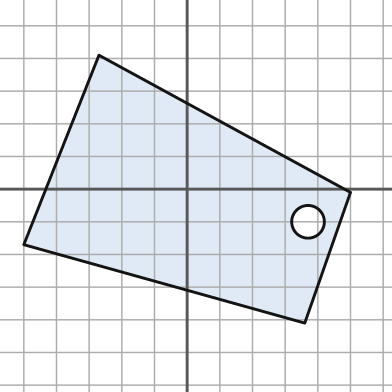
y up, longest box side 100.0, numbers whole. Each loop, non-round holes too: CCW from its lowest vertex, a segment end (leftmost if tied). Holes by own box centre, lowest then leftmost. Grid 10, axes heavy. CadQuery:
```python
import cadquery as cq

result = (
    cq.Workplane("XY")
    .moveTo(36.0, -41.0)
    .lineTo(50.0, -1.0)
    .lineTo(-27.0, 41.0)
    .lineTo(-50.0, -17.0)
    .close()
    .moveTo(37.0, -10.0)
    .circle(5.0)
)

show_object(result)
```